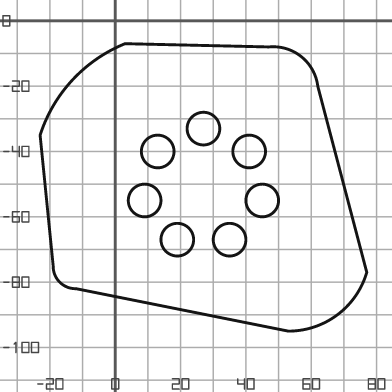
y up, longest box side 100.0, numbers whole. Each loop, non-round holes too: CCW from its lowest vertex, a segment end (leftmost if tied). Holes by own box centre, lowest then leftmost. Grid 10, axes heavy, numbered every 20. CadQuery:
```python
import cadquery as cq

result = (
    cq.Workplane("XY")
    .moveTo(53.0, -95.0)
    .threePointArc((68.0, -90.0), (77.0, -77.0))
    .lineTo(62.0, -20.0)
    .threePointArc((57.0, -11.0), (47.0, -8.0))
    .lineTo(3.0, -7.0)
    .threePointArc((-13.0, -18.0), (-23.0, -35.0))
    .lineTo(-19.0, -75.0)
    .threePointArc((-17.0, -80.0), (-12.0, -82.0))
    .close()
    .moveTo(19.0, -67.0)
    .circle(5.0)
    .moveTo(35.0, -67.0)
    .circle(5.0)
    .moveTo(9.0, -55.0)
    .circle(5.0)
    .moveTo(45.0, -55.0)
    .circle(5.0)
    .moveTo(13.0, -40.0)
    .circle(5.0)
    .moveTo(41.0, -40.0)
    .circle(5.0)
    .moveTo(27.0, -33.0)
    .circle(5.0)
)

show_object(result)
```